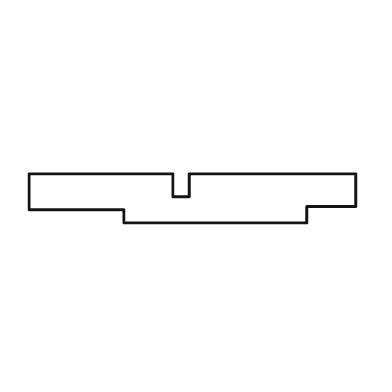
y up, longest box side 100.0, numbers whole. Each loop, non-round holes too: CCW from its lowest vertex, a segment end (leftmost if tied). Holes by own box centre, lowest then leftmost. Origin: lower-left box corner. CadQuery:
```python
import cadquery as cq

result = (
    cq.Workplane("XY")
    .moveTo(29.0, 0.0)
    .lineTo(85.0, 0.0)
    .lineTo(85.0, 5.0)
    .lineTo(100.0, 5.0)
    .lineTo(100.0, 15.0)
    .lineTo(49.0, 15.0)
    .lineTo(49.0, 8.0)
    .lineTo(44.0, 8.0)
    .lineTo(44.0, 15.0)
    .lineTo(0.0, 15.0)
    .lineTo(0.0, 4.0)
    .lineTo(29.0, 4.0)
    .close()
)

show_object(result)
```